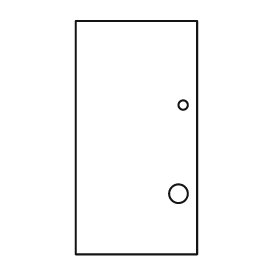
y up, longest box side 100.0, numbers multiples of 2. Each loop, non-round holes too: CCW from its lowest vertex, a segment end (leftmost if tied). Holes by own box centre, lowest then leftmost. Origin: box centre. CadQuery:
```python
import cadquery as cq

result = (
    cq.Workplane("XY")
    .moveTo(-26.0, -50.0)
    .lineTo(26.0, -50.0)
    .lineTo(26.0, 50.0)
    .lineTo(-26.0, 50.0)
    .close()
    .moveTo(18.0, -24.0)
    .circle(4.0)
    .moveTo(20.0, 14.0)
    .circle(2.0)
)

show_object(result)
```